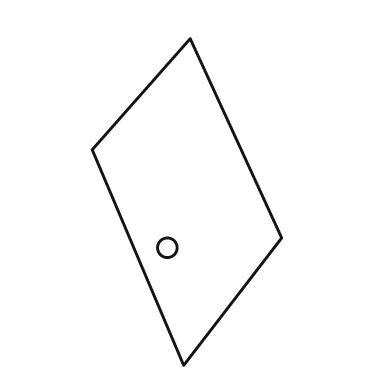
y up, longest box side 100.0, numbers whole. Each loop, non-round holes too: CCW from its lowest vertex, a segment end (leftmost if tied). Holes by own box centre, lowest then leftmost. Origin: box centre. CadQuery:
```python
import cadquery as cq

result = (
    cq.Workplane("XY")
    .moveTo(-1.0, -50.0)
    .lineTo(29.0, -11.0)
    .lineTo(1.0, 50.0)
    .lineTo(-29.0, 16.0)
    .close()
    .moveTo(-6.0, -14.0)
    .circle(3.0)
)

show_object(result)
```